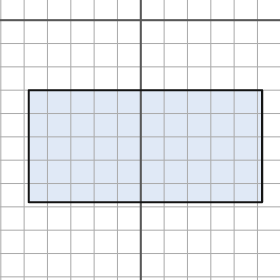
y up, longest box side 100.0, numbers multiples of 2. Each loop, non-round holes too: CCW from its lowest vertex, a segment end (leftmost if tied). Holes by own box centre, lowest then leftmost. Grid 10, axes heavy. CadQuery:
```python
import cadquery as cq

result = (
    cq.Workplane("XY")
    .moveTo(-48.0, -78.0)
    .lineTo(52.0, -78.0)
    .lineTo(52.0, -30.0)
    .lineTo(-48.0, -30.0)
    .close()
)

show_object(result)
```